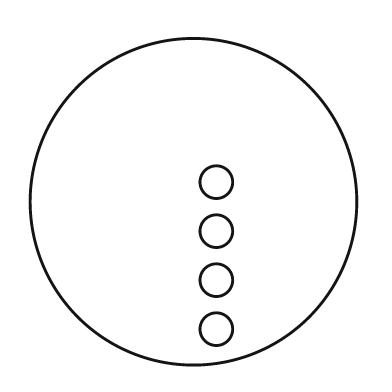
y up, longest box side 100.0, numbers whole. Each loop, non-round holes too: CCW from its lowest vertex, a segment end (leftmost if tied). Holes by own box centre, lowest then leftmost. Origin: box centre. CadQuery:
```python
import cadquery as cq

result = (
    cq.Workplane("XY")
    .moveTo(0.0, 0.0)
    .circle(50.0)
    .moveTo(7.0, -39.0)
    .circle(5.0)
    .moveTo(7.0, -24.0)
    .circle(5.0)
    .moveTo(7.0, -9.0)
    .circle(5.0)
    .moveTo(7.0, 6.0)
    .circle(5.0)
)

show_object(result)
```